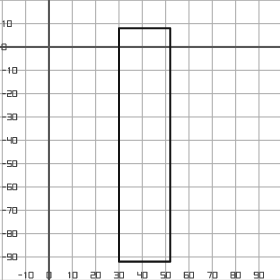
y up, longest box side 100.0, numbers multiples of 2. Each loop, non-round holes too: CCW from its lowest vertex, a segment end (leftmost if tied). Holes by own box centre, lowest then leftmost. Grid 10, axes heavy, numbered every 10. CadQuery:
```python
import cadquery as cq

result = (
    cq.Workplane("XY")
    .moveTo(30.0, -92.0)
    .lineTo(52.0, -92.0)
    .lineTo(52.0, 8.0)
    .lineTo(30.0, 8.0)
    .close()
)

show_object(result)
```